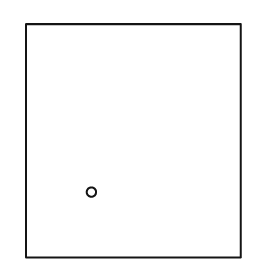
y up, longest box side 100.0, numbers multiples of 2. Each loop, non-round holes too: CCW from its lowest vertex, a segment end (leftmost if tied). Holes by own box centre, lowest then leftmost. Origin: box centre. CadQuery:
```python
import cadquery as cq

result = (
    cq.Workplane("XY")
    .moveTo(-46.0, -50.0)
    .lineTo(46.0, -50.0)
    .lineTo(46.0, 50.0)
    .lineTo(-46.0, 50.0)
    .close()
    .moveTo(-18.0, -22.0)
    .circle(2.0)
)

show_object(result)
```